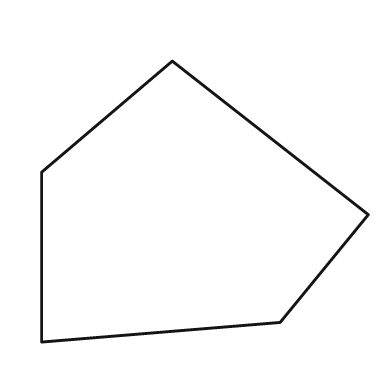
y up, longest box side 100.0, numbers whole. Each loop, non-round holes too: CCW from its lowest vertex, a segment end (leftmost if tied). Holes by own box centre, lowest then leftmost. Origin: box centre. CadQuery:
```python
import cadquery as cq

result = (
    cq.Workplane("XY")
    .moveTo(-50.0, -43.0)
    .lineTo(23.0, -37.0)
    .lineTo(50.0, -4.0)
    .lineTo(-10.0, 43.0)
    .lineTo(-50.0, 9.0)
    .close()
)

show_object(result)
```